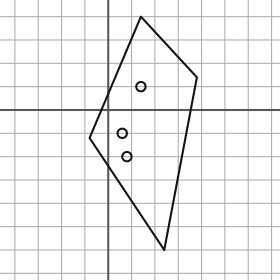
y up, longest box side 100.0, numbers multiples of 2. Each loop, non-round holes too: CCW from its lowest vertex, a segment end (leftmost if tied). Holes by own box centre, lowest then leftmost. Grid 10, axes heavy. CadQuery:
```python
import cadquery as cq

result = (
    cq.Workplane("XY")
    .moveTo(24.0, -60.0)
    .lineTo(38.0, 14.0)
    .lineTo(14.0, 40.0)
    .lineTo(-8.0, -12.0)
    .close()
    .moveTo(8.0, -20.0)
    .circle(2.0)
    .moveTo(6.0, -10.0)
    .circle(2.0)
    .moveTo(14.0, 10.0)
    .circle(2.0)
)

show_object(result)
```